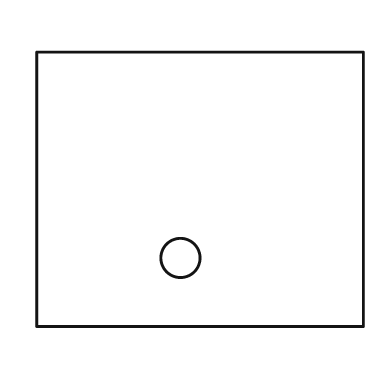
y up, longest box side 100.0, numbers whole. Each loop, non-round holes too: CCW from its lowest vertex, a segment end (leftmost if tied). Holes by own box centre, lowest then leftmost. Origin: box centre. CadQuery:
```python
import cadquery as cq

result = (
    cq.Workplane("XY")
    .moveTo(-50.0, -42.0)
    .lineTo(50.0, -42.0)
    .lineTo(50.0, 42.0)
    .lineTo(-50.0, 42.0)
    .close()
    .moveTo(-6.0, -21.0)
    .circle(6.0)
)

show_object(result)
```